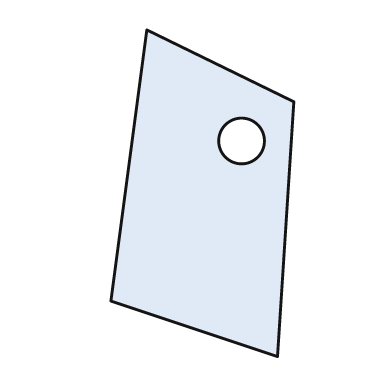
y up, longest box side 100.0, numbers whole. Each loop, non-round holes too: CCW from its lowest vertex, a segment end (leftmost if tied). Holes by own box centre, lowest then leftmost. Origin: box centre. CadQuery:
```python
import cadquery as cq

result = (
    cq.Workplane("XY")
    .moveTo(23.0, -50.0)
    .lineTo(28.0, 28.0)
    .lineTo(-17.0, 50.0)
    .lineTo(-28.0, -33.0)
    .close()
    .moveTo(12.0, 16.0)
    .circle(7.0)
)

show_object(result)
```